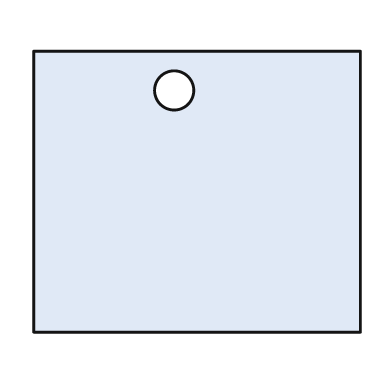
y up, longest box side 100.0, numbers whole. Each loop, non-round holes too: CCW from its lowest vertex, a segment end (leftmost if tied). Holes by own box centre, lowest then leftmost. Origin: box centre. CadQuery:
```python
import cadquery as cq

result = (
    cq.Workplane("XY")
    .moveTo(-50.0, -43.0)
    .lineTo(50.0, -43.0)
    .lineTo(50.0, 43.0)
    .lineTo(-50.0, 43.0)
    .close()
    .moveTo(-7.0, 31.0)
    .circle(6.0)
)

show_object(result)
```